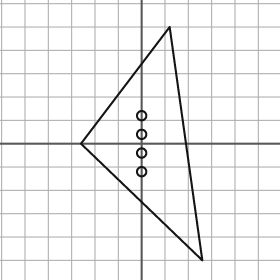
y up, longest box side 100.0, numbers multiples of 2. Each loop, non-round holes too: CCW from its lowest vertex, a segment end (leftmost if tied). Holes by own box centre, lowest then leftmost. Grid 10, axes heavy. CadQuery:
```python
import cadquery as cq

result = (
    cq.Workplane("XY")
    .moveTo(26.0, -50.0)
    .lineTo(12.0, 50.0)
    .lineTo(-26.0, 0.0)
    .close()
    .moveTo(0.0, -12.0)
    .circle(2.0)
    .moveTo(0.0, -4.0)
    .circle(2.0)
    .moveTo(0.0, 4.0)
    .circle(2.0)
    .moveTo(0.0, 12.0)
    .circle(2.0)
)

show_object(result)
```